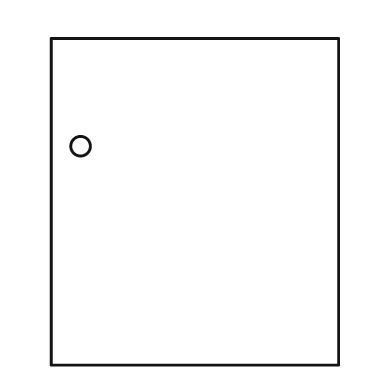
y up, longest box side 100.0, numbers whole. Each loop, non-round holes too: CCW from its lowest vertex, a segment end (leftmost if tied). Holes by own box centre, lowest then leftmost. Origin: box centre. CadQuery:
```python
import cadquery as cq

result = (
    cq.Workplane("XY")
    .moveTo(-44.0, -50.0)
    .lineTo(44.0, -50.0)
    .lineTo(44.0, 50.0)
    .lineTo(-44.0, 50.0)
    .close()
    .moveTo(-35.0, 17.0)
    .circle(3.0)
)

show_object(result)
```